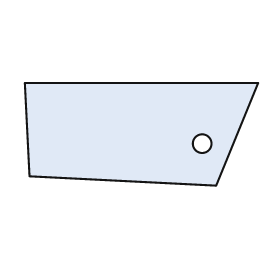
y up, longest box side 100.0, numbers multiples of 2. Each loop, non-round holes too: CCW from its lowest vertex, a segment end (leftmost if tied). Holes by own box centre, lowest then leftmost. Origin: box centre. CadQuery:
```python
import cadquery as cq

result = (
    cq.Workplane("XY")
    .moveTo(32.0, -22.0)
    .lineTo(50.0, 22.0)
    .lineTo(-50.0, 22.0)
    .lineTo(-48.0, -18.0)
    .close()
    .moveTo(26.0, -4.0)
    .circle(4.0)
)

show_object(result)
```